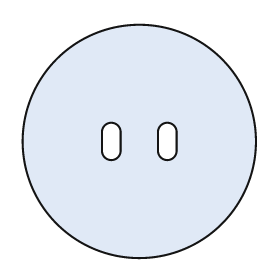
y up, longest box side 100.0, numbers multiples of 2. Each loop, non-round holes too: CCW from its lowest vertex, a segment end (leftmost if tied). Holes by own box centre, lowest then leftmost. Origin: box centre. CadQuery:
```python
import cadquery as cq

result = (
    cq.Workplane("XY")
    .moveTo(0.0, 0.0)
    .circle(50.0)
    .moveTo(-16.0, -4.0)
    .threePointArc((-12.0, -8.0), (-8.0, -4.0))
    .lineTo(-8.0, 4.0)
    .threePointArc((-12.0, 8.0), (-16.0, 4.0))
    .close()
    .moveTo(8.0, -4.0)
    .threePointArc((12.0, -8.0), (16.0, -4.0))
    .lineTo(16.0, 4.0)
    .threePointArc((12.0, 8.0), (8.0, 4.0))
    .close()
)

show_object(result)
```